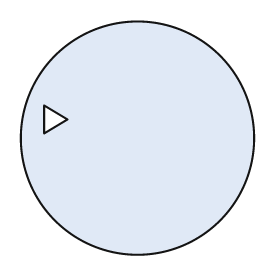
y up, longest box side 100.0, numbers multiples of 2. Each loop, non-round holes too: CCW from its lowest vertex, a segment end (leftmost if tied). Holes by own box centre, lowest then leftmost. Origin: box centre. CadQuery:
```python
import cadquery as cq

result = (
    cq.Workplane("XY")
    .moveTo(0.0, 0.0)
    .circle(50.0)
    .moveTo(-40.0, 2.0)
    .lineTo(-30.0, 8.0)
    .lineTo(-40.0, 14.0)
    .close()
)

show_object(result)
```